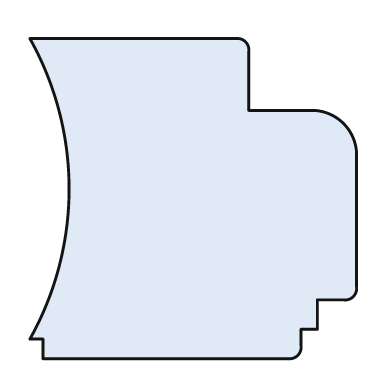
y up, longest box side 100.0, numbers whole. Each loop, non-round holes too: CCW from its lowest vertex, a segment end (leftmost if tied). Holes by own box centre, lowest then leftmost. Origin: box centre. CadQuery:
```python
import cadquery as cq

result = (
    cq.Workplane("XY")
    .moveTo(-46.0, -49.0)
    .lineTo(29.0, -49.0)
    .threePointArc((32.0, -48.0), (33.0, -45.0))
    .lineTo(33.0, -40.0)
    .lineTo(38.0, -40.0)
    .lineTo(38.0, -31.0)
    .lineTo(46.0, -31.0)
    .threePointArc((49.0, -30.0), (50.0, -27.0))
    .lineTo(50.0, 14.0)
    .threePointArc((46.0, 23.0), (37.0, 27.0))
    .lineTo(17.0, 27.0)
    .lineTo(17.0, 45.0)
    .threePointArc((16.0, 48.0), (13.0, 49.0))
    .lineTo(-50.0, 49.0)
    .threePointArc((-38.0, 3.0), (-50.0, -43.0))
    .lineTo(-46.0, -43.0)
    .close()
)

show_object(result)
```